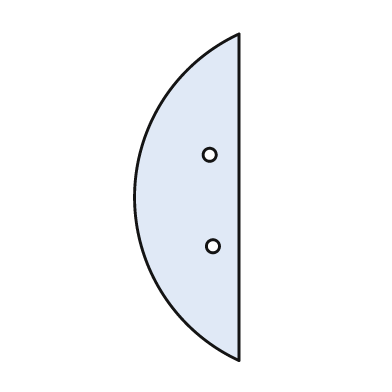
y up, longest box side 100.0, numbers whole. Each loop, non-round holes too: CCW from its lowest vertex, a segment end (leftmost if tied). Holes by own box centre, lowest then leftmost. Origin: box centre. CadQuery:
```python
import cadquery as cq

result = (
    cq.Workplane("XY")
    .moveTo(16.0, -50.0)
    .lineTo(16.0, 50.0)
    .threePointArc((-16.0, 0.0), (16.0, -50.0))
    .close()
    .moveTo(8.0, -15.0)
    .circle(2.0)
    .moveTo(7.0, 13.0)
    .circle(2.0)
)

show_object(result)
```